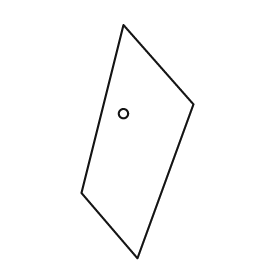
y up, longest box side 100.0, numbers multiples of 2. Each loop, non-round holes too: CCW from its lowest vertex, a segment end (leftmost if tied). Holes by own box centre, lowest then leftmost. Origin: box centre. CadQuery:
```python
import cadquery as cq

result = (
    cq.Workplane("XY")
    .moveTo(0.0, -50.0)
    .lineTo(24.0, 16.0)
    .lineTo(-6.0, 50.0)
    .lineTo(-24.0, -22.0)
    .close()
    .moveTo(-6.0, 12.0)
    .circle(2.0)
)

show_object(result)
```